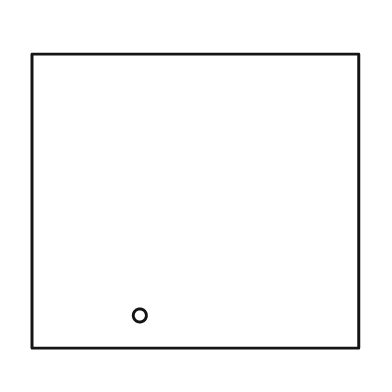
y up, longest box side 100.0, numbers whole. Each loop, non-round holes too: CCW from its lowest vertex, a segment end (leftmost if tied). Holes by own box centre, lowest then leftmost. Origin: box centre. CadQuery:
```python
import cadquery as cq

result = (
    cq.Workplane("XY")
    .moveTo(-50.0, -45.0)
    .lineTo(50.0, -45.0)
    .lineTo(50.0, 45.0)
    .lineTo(-50.0, 45.0)
    .close()
    .moveTo(-17.0, -35.0)
    .circle(2.0)
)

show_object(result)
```